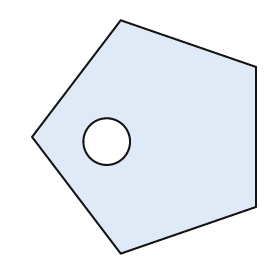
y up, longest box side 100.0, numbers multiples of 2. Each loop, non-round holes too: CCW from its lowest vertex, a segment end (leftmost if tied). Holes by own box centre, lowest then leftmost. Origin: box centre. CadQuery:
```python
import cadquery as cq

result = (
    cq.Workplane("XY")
    .moveTo(-10.0, -50.0)
    .lineTo(48.0, -30.0)
    .lineTo(48.0, 30.0)
    .lineTo(-10.0, 50.0)
    .lineTo(-48.0, 0.0)
    .close()
    .moveTo(-16.0, -2.0)
    .circle(10.0)
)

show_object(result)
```